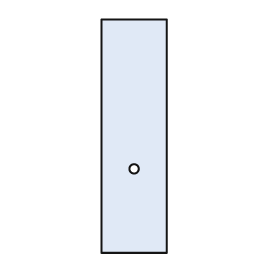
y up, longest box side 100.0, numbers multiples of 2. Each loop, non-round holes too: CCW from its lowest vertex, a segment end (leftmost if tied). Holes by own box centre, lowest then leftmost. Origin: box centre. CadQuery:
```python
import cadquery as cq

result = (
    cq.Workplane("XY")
    .moveTo(-14.0, -50.0)
    .lineTo(14.0, -50.0)
    .lineTo(14.0, 50.0)
    .lineTo(-14.0, 50.0)
    .close()
    .moveTo(0.0, -14.0)
    .circle(2.0)
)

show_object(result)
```